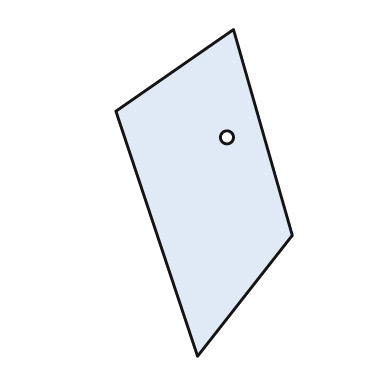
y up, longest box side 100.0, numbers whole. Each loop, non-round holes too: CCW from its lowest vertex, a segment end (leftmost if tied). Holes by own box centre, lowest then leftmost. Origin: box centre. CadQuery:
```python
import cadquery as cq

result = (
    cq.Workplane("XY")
    .moveTo(-2.0, -50.0)
    .lineTo(27.0, -13.0)
    .lineTo(9.0, 50.0)
    .lineTo(-27.0, 25.0)
    .close()
    .moveTo(7.0, 17.0)
    .circle(2.0)
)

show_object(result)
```